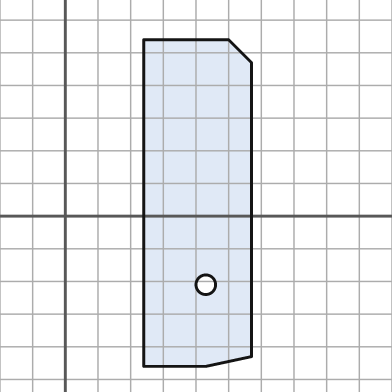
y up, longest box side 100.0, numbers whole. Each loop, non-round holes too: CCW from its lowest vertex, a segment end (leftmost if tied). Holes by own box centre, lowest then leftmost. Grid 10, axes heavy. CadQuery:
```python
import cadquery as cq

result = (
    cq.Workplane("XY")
    .moveTo(24.0, -46.0)
    .lineTo(43.0, -46.0)
    .lineTo(57.0, -43.0)
    .lineTo(57.0, 47.0)
    .lineTo(50.0, 54.0)
    .lineTo(24.0, 54.0)
    .close()
    .moveTo(43.0, -21.0)
    .circle(3.0)
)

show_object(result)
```